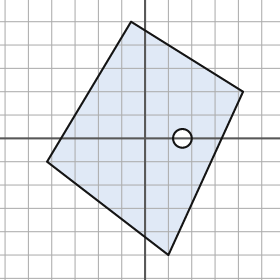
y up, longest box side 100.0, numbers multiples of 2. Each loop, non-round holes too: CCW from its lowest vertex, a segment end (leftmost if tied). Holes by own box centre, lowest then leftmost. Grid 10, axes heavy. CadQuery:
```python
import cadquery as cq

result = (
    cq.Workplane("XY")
    .moveTo(10.0, -50.0)
    .lineTo(42.0, 20.0)
    .lineTo(-6.0, 50.0)
    .lineTo(-42.0, -10.0)
    .close()
    .moveTo(16.0, 0.0)
    .circle(4.0)
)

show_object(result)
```